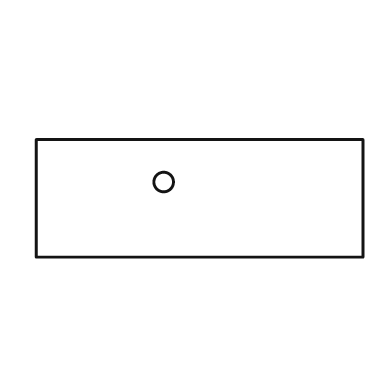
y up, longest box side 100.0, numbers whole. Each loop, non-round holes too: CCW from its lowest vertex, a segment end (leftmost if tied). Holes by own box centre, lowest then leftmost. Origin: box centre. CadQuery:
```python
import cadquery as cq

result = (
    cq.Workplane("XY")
    .moveTo(-50.0, -18.0)
    .lineTo(50.0, -18.0)
    .lineTo(50.0, 18.0)
    .lineTo(-50.0, 18.0)
    .close()
    .moveTo(-11.0, 5.0)
    .circle(3.0)
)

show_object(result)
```